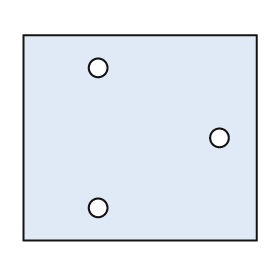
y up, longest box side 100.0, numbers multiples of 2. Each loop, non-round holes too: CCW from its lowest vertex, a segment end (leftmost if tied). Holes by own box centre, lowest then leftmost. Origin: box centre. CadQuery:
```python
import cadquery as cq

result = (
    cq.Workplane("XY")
    .moveTo(-50.0, -44.0)
    .lineTo(50.0, -44.0)
    .lineTo(50.0, 44.0)
    .lineTo(-50.0, 44.0)
    .close()
    .moveTo(-18.0, -30.0)
    .circle(4.0)
    .moveTo(34.0, 0.0)
    .circle(4.0)
    .moveTo(-18.0, 30.0)
    .circle(4.0)
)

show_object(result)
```